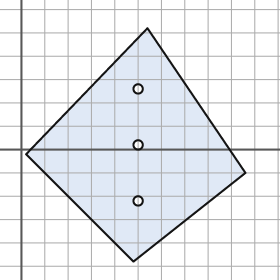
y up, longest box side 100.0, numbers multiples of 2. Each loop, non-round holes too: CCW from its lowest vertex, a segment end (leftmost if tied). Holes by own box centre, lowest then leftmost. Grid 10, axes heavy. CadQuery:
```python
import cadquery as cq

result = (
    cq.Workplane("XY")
    .moveTo(48.0, -48.0)
    .lineTo(96.0, -10.0)
    .lineTo(54.0, 52.0)
    .lineTo(2.0, -2.0)
    .close()
    .moveTo(50.0, -22.0)
    .circle(2.0)
    .moveTo(50.0, 2.0)
    .circle(2.0)
    .moveTo(50.0, 26.0)
    .circle(2.0)
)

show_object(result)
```